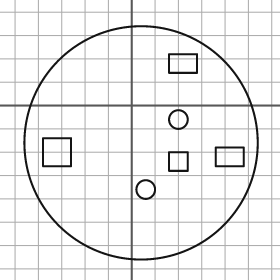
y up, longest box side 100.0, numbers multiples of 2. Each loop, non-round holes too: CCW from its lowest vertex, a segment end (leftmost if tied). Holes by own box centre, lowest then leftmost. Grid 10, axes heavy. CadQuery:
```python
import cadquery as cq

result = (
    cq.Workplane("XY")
    .moveTo(4.0, -16.0)
    .circle(50.0)
    .moveTo(6.0, -36.0)
    .circle(4.0)
    .moveTo(16.0, -28.0)
    .lineTo(24.0, -28.0)
    .lineTo(24.0, -20.0)
    .lineTo(16.0, -20.0)
    .close()
    .moveTo(36.0, -26.0)
    .lineTo(48.0, -26.0)
    .lineTo(48.0, -18.0)
    .lineTo(36.0, -18.0)
    .close()
    .moveTo(-38.0, -26.0)
    .lineTo(-26.0, -26.0)
    .lineTo(-26.0, -14.0)
    .lineTo(-38.0, -14.0)
    .close()
    .moveTo(20.0, -6.0)
    .circle(4.0)
    .moveTo(16.0, 14.0)
    .lineTo(28.0, 14.0)
    .lineTo(28.0, 22.0)
    .lineTo(16.0, 22.0)
    .close()
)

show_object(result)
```